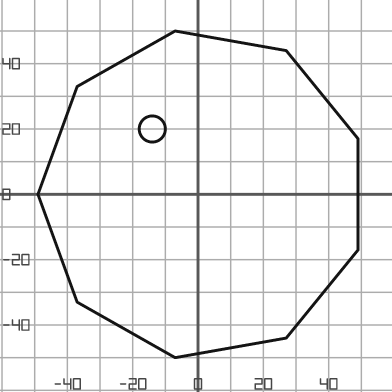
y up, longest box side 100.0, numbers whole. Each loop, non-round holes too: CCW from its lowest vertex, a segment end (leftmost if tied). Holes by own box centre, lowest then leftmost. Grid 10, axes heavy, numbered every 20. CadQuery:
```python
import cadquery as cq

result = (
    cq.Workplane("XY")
    .moveTo(-7.0, -50.0)
    .lineTo(27.0, -44.0)
    .lineTo(49.0, -17.0)
    .lineTo(49.0, 17.0)
    .lineTo(27.0, 44.0)
    .lineTo(-7.0, 50.0)
    .lineTo(-37.0, 33.0)
    .lineTo(-49.0, 0.0)
    .lineTo(-37.0, -33.0)
    .close()
    .moveTo(-14.0, 20.0)
    .circle(4.0)
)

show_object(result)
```